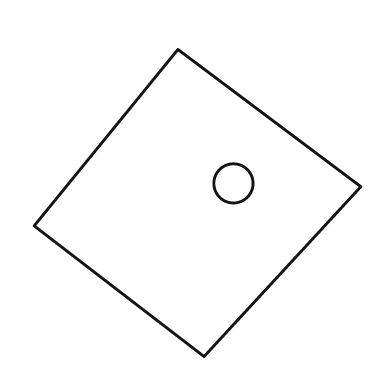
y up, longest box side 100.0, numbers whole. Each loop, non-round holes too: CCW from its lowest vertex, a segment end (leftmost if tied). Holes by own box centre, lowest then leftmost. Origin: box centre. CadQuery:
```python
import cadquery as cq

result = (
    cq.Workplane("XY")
    .moveTo(2.0, -47.0)
    .lineTo(50.0, 5.0)
    .lineTo(-6.0, 47.0)
    .lineTo(-50.0, -7.0)
    .close()
    .moveTo(11.0, 6.0)
    .circle(6.0)
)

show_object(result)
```